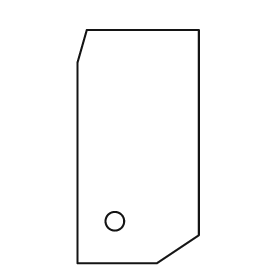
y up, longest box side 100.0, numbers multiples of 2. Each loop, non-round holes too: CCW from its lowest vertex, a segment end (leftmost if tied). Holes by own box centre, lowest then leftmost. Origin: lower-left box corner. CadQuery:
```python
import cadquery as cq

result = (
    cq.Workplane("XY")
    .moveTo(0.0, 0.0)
    .lineTo(34.0, 0.0)
    .lineTo(52.0, 12.0)
    .lineTo(52.0, 100.0)
    .lineTo(4.0, 100.0)
    .lineTo(0.0, 86.0)
    .close()
    .moveTo(16.0, 18.0)
    .circle(4.0)
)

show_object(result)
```